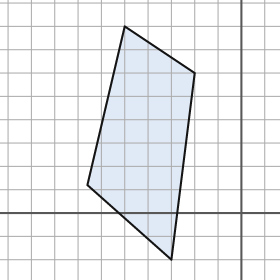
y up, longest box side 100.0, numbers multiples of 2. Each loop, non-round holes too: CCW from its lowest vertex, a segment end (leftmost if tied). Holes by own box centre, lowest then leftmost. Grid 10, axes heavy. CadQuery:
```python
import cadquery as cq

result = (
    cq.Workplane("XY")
    .moveTo(-30.0, -20.0)
    .lineTo(-20.0, 60.0)
    .lineTo(-50.0, 80.0)
    .lineTo(-66.0, 12.0)
    .close()
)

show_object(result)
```